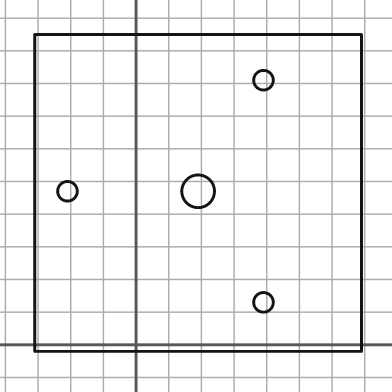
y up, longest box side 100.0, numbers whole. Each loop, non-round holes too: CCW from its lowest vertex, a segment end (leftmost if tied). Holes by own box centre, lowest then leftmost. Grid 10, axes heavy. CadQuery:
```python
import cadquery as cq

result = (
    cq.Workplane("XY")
    .moveTo(-31.0, -2.0)
    .lineTo(69.0, -2.0)
    .lineTo(69.0, 95.0)
    .lineTo(-31.0, 95.0)
    .close()
    .moveTo(39.0, 13.0)
    .circle(3.0)
    .moveTo(-21.0, 47.0)
    .circle(3.0)
    .moveTo(19.0, 47.0)
    .circle(5.0)
    .moveTo(39.0, 81.0)
    .circle(3.0)
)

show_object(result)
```